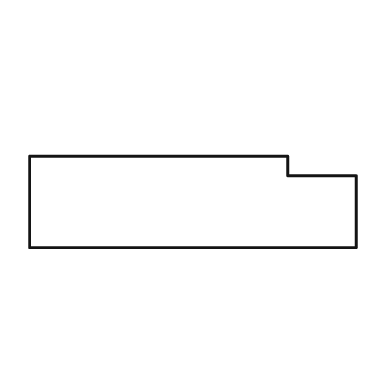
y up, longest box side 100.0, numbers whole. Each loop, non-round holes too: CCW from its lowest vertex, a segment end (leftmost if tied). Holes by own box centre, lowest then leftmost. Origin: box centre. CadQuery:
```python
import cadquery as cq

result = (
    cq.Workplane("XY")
    .moveTo(-50.0, -14.0)
    .lineTo(50.0, -14.0)
    .lineTo(50.0, 8.0)
    .lineTo(29.0, 8.0)
    .lineTo(29.0, 14.0)
    .lineTo(-50.0, 14.0)
    .close()
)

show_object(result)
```